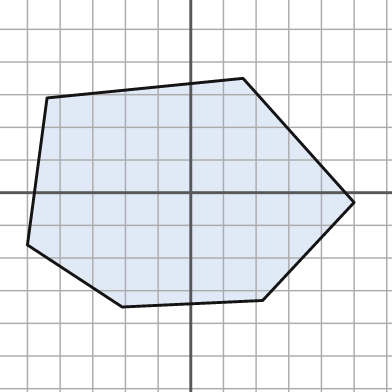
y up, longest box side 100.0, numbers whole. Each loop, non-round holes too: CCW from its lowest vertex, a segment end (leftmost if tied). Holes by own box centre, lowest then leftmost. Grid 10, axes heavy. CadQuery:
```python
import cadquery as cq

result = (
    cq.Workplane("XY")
    .moveTo(-21.0, -35.0)
    .lineTo(22.0, -33.0)
    .lineTo(50.0, -3.0)
    .lineTo(16.0, 35.0)
    .lineTo(-44.0, 29.0)
    .lineTo(-50.0, -16.0)
    .close()
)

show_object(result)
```